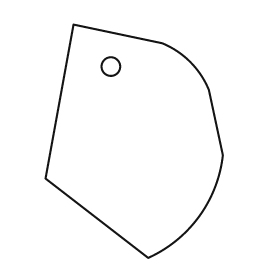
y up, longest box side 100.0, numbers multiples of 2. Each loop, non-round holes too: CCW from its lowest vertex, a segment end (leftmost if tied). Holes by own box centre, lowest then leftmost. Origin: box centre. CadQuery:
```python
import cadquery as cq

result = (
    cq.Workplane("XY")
    .moveTo(6.0, -50.0)
    .threePointArc((28.0, -32.0), (38.0, -6.0))
    .lineTo(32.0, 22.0)
    .threePointArc((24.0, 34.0), (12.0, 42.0))
    .lineTo(-26.0, 50.0)
    .lineTo(-38.0, -16.0)
    .close()
    .moveTo(-10.0, 32.0)
    .circle(4.0)
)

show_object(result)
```